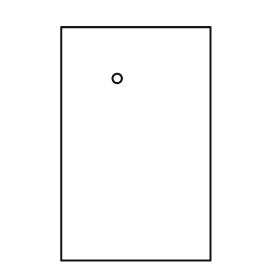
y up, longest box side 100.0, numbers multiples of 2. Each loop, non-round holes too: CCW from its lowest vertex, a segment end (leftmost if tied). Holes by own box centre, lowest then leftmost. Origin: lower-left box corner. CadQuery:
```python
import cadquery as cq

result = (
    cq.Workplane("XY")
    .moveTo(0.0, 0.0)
    .lineTo(64.0, 0.0)
    .lineTo(64.0, 100.0)
    .lineTo(0.0, 100.0)
    .close()
    .moveTo(24.0, 78.0)
    .circle(2.0)
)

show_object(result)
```